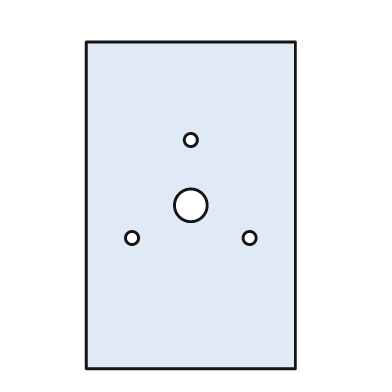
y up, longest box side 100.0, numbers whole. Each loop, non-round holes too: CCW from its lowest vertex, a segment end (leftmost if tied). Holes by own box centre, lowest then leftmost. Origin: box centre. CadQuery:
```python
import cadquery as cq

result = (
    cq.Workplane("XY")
    .moveTo(-32.0, -50.0)
    .lineTo(32.0, -50.0)
    .lineTo(32.0, 50.0)
    .lineTo(-32.0, 50.0)
    .close()
    .moveTo(-18.0, -10.0)
    .circle(2.0)
    .moveTo(18.0, -10.0)
    .circle(2.0)
    .moveTo(0.0, 0.0)
    .circle(5.0)
    .moveTo(0.0, 20.0)
    .circle(2.0)
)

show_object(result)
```